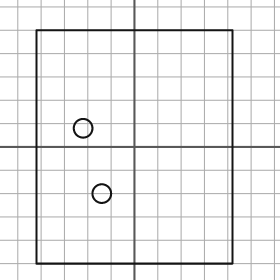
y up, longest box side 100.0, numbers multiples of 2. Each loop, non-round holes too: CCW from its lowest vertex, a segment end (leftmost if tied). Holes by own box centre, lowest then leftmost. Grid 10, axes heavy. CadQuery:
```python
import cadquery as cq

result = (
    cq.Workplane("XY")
    .moveTo(-42.0, -50.0)
    .lineTo(42.0, -50.0)
    .lineTo(42.0, 50.0)
    .lineTo(-42.0, 50.0)
    .close()
    .moveTo(-14.0, -20.0)
    .circle(4.0)
    .moveTo(-22.0, 8.0)
    .circle(4.0)
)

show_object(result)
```